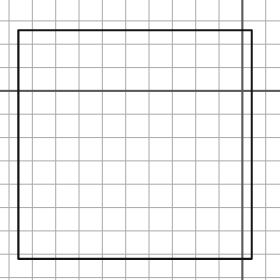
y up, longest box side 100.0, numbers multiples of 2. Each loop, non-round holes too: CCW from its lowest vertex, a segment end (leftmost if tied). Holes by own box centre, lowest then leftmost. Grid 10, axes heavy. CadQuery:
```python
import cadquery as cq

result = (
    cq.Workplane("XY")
    .moveTo(-96.0, -72.0)
    .lineTo(4.0, -72.0)
    .lineTo(4.0, 26.0)
    .lineTo(-96.0, 26.0)
    .close()
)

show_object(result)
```